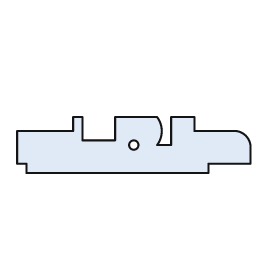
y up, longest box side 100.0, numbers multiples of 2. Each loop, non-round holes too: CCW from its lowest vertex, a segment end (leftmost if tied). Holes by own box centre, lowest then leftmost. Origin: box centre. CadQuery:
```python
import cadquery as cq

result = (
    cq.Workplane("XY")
    .moveTo(-46.0, -12.0)
    .lineTo(32.0, -12.0)
    .lineTo(32.0, -8.0)
    .lineTo(50.0, -8.0)
    .lineTo(50.0, 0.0)
    .threePointArc((48.0, 4.0), (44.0, 6.0))
    .lineTo(26.0, 6.0)
    .lineTo(26.0, 12.0)
    .lineTo(16.0, 12.0)
    .lineTo(16.0, 0.0)
    .lineTo(10.0, 0.0)
    .threePointArc((12.0, 6.0), (10.0, 12.0))
    .lineTo(-8.0, 12.0)
    .lineTo(-8.0, 2.0)
    .lineTo(-22.0, 2.0)
    .lineTo(-22.0, 12.0)
    .lineTo(-26.0, 12.0)
    .lineTo(-26.0, 6.0)
    .lineTo(-50.0, 6.0)
    .lineTo(-50.0, -8.0)
    .lineTo(-46.0, -8.0)
    .close()
    .moveTo(0.0, 0.0)
    .circle(2.0)
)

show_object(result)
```